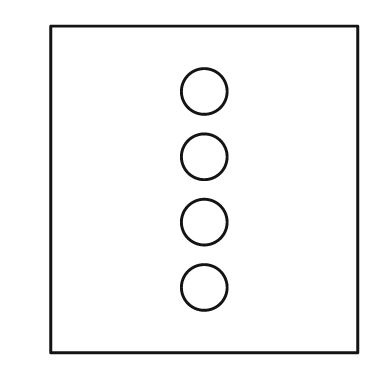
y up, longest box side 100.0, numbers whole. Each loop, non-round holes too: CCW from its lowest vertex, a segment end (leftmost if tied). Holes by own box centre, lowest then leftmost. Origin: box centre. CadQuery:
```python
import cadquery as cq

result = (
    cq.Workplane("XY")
    .moveTo(-47.0, -50.0)
    .lineTo(47.0, -50.0)
    .lineTo(47.0, 50.0)
    .lineTo(-47.0, 50.0)
    .close()
    .moveTo(0.0, -30.0)
    .circle(7.0)
    .moveTo(0.0, -10.0)
    .circle(7.0)
    .moveTo(0.0, 10.0)
    .circle(7.0)
    .moveTo(0.0, 30.0)
    .circle(7.0)
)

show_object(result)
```